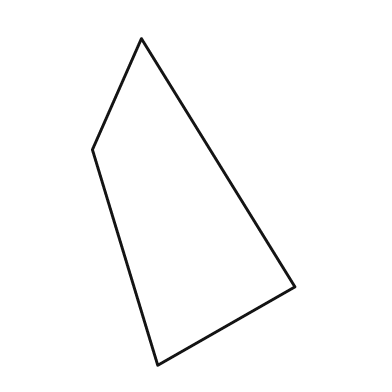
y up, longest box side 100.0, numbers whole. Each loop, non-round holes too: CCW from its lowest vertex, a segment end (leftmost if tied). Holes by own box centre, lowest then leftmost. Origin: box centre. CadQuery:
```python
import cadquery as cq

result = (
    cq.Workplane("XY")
    .moveTo(-11.0, -50.0)
    .lineTo(31.0, -26.0)
    .lineTo(-16.0, 50.0)
    .lineTo(-31.0, 16.0)
    .close()
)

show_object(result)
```